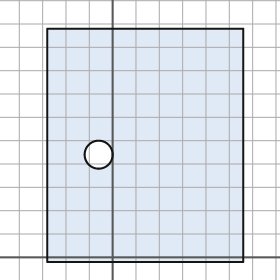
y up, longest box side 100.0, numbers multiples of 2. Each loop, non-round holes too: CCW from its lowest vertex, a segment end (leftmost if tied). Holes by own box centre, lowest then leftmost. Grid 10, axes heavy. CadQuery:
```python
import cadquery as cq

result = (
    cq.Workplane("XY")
    .moveTo(-28.0, -2.0)
    .lineTo(56.0, -2.0)
    .lineTo(56.0, 98.0)
    .lineTo(-28.0, 98.0)
    .close()
    .moveTo(-6.0, 44.0)
    .circle(6.0)
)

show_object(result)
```